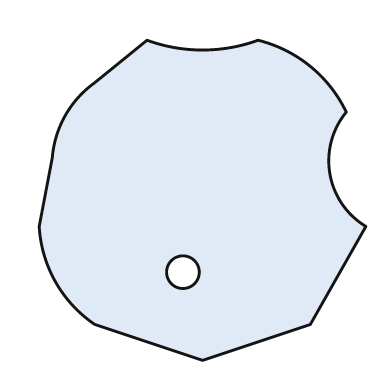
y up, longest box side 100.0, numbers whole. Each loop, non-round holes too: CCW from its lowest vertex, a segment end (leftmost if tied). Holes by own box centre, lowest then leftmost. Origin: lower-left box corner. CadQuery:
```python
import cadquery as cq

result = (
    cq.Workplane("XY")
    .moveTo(50.0, 0.0)
    .lineTo(83.0, 11.0)
    .lineTo(100.0, 41.0)
    .threePointArc((89.0, 57.0), (94.0, 76.0))
    .threePointArc((83.0, 90.0), (67.0, 98.0))
    .threePointArc((50.0, 95.0), (33.0, 98.0))
    .lineTo(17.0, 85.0)
    .threePointArc((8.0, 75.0), (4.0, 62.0))
    .lineTo(0.0, 41.0)
    .threePointArc((5.0, 24.0), (17.0, 11.0))
    .close()
    .moveTo(44.0, 27.0)
    .circle(5.0)
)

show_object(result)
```